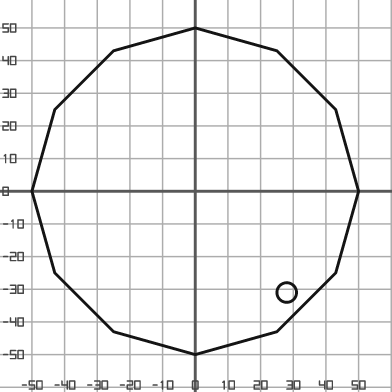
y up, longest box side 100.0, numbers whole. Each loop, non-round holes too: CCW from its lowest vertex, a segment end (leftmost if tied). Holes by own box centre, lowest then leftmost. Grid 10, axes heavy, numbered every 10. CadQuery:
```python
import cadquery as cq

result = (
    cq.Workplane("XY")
    .moveTo(0.0, -50.0)
    .lineTo(25.0, -43.0)
    .lineTo(43.0, -25.0)
    .lineTo(50.0, 0.0)
    .lineTo(43.0, 25.0)
    .lineTo(25.0, 43.0)
    .lineTo(0.0, 50.0)
    .lineTo(-25.0, 43.0)
    .lineTo(-43.0, 25.0)
    .lineTo(-50.0, 0.0)
    .lineTo(-43.0, -25.0)
    .lineTo(-25.0, -43.0)
    .close()
    .moveTo(28.0, -31.0)
    .circle(3.0)
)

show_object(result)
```